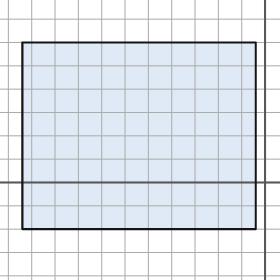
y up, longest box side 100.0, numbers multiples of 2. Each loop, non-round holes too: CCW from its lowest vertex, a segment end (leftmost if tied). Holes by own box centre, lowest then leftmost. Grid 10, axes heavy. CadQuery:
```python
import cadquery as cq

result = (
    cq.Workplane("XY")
    .moveTo(-104.0, -20.0)
    .lineTo(-4.0, -20.0)
    .lineTo(-4.0, 60.0)
    .lineTo(-104.0, 60.0)
    .close()
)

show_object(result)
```